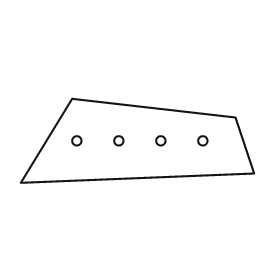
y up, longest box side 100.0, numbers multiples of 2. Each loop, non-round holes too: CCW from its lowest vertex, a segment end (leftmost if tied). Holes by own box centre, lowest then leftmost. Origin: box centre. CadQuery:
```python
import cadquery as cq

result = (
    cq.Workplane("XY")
    .moveTo(-50.0, -18.0)
    .lineTo(50.0, -14.0)
    .lineTo(42.0, 10.0)
    .lineTo(-28.0, 18.0)
    .close()
    .moveTo(-26.0, 0.0)
    .circle(2.0)
    .moveTo(-8.0, 0.0)
    .circle(2.0)
    .moveTo(10.0, 0.0)
    .circle(2.0)
    .moveTo(28.0, 0.0)
    .circle(2.0)
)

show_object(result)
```